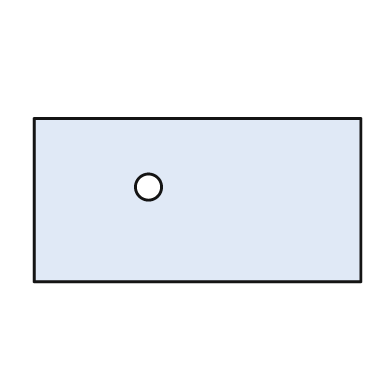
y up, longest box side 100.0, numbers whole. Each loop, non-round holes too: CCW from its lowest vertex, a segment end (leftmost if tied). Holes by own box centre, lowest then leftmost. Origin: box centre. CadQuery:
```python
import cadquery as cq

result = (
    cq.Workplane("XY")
    .moveTo(-50.0, -25.0)
    .lineTo(50.0, -25.0)
    .lineTo(50.0, 25.0)
    .lineTo(-50.0, 25.0)
    .close()
    .moveTo(-15.0, 4.0)
    .circle(4.0)
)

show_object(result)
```